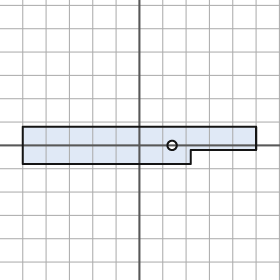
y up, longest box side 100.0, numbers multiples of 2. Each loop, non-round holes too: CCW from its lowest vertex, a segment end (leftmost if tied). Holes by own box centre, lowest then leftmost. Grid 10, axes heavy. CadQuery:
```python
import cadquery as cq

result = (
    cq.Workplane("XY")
    .moveTo(-50.0, -8.0)
    .lineTo(22.0, -8.0)
    .lineTo(22.0, -2.0)
    .lineTo(50.0, -2.0)
    .lineTo(50.0, 8.0)
    .lineTo(-50.0, 8.0)
    .close()
    .moveTo(14.0, 0.0)
    .circle(2.0)
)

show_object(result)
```